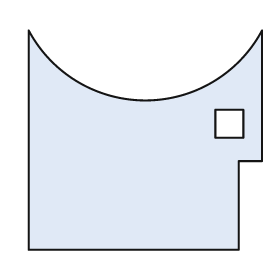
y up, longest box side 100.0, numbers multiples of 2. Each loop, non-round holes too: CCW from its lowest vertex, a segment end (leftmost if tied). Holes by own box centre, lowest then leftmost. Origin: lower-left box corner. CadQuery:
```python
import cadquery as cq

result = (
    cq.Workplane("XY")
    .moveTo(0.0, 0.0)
    .lineTo(90.0, 0.0)
    .lineTo(90.0, 38.0)
    .lineTo(100.0, 38.0)
    .lineTo(100.0, 94.0)
    .threePointArc((50.0, 64.0), (0.0, 94.0))
    .close()
    .moveTo(80.0, 48.0)
    .lineTo(92.0, 48.0)
    .lineTo(92.0, 60.0)
    .lineTo(80.0, 60.0)
    .close()
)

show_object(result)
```